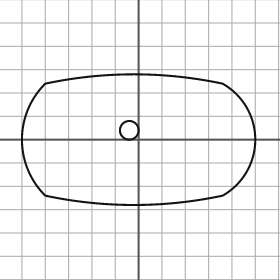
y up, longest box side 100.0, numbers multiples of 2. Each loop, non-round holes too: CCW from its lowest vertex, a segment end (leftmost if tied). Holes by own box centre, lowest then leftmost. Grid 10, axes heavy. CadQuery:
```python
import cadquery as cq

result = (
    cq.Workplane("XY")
    .moveTo(-40.0, -24.0)
    .threePointArc((-2.0, -28.0), (36.0, -24.0))
    .threePointArc((50.0, 0.0), (36.0, 24.0))
    .threePointArc((-2.0, 28.0), (-40.0, 24.0))
    .threePointArc((-50.0, 0.0), (-40.0, -24.0))
    .close()
    .moveTo(-4.0, 4.0)
    .circle(4.0)
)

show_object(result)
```